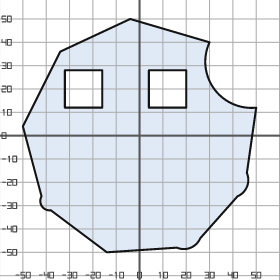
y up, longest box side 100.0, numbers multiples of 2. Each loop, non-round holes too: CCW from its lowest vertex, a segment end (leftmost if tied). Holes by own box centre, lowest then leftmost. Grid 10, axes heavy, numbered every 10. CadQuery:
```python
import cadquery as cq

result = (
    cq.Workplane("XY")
    .moveTo(-14.0, -50.0)
    .lineTo(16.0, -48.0)
    .threePointArc((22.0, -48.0), (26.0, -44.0))
    .lineTo(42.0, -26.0)
    .threePointArc((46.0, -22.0), (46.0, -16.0))
    .lineTo(50.0, 12.0)
    .threePointArc((32.0, 20.0), (30.0, 40.0))
    .lineTo(-4.0, 50.0)
    .lineTo(-34.0, 36.0)
    .lineTo(-50.0, 4.0)
    .lineTo(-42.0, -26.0)
    .threePointArc((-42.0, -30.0), (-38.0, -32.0))
    .close()
    .moveTo(-32.0, 12.0)
    .lineTo(-16.0, 12.0)
    .lineTo(-16.0, 28.0)
    .lineTo(-32.0, 28.0)
    .close()
    .moveTo(4.0, 12.0)
    .lineTo(20.0, 12.0)
    .lineTo(20.0, 28.0)
    .lineTo(4.0, 28.0)
    .close()
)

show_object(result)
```